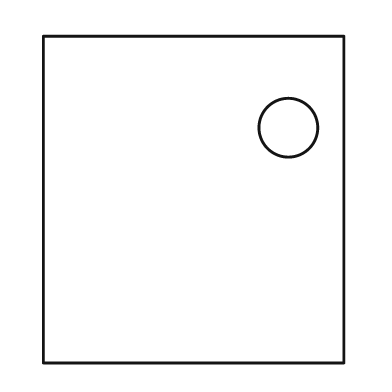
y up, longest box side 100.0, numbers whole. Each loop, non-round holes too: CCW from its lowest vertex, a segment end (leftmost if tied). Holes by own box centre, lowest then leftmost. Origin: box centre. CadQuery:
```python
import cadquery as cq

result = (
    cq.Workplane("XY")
    .moveTo(-46.0, -50.0)
    .lineTo(46.0, -50.0)
    .lineTo(46.0, 50.0)
    .lineTo(-46.0, 50.0)
    .close()
    .moveTo(29.0, 22.0)
    .circle(9.0)
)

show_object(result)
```